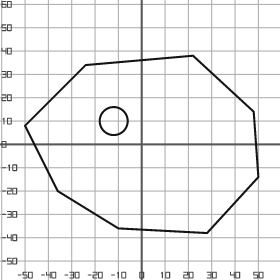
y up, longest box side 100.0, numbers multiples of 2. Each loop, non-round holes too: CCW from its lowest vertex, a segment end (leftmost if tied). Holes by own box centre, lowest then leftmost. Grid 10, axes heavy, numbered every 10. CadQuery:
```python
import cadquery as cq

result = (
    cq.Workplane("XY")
    .moveTo(28.0, -38.0)
    .lineTo(50.0, -14.0)
    .lineTo(48.0, 14.0)
    .lineTo(22.0, 38.0)
    .lineTo(-24.0, 34.0)
    .lineTo(-50.0, 8.0)
    .lineTo(-36.0, -20.0)
    .lineTo(-10.0, -36.0)
    .close()
    .moveTo(-12.0, 10.0)
    .circle(6.0)
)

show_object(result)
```